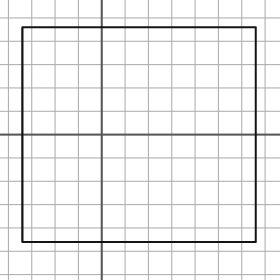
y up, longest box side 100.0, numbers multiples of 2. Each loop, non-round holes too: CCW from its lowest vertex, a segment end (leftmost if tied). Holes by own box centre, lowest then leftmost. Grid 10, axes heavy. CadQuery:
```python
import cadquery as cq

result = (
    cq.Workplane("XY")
    .moveTo(-34.0, -46.0)
    .lineTo(66.0, -46.0)
    .lineTo(66.0, 46.0)
    .lineTo(-34.0, 46.0)
    .close()
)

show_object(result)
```